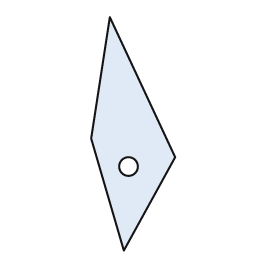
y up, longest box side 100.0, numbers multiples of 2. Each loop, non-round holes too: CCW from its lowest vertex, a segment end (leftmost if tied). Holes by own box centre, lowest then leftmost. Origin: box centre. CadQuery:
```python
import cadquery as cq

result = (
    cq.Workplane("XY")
    .moveTo(-4.0, -50.0)
    .lineTo(18.0, -10.0)
    .lineTo(-10.0, 50.0)
    .lineTo(-18.0, -2.0)
    .close()
    .moveTo(-2.0, -14.0)
    .circle(4.0)
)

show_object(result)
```